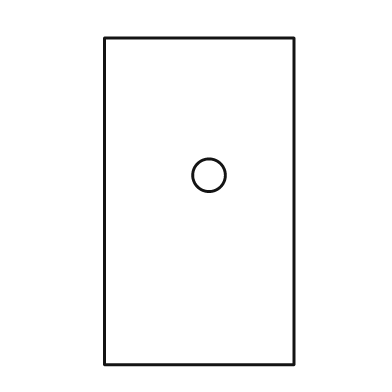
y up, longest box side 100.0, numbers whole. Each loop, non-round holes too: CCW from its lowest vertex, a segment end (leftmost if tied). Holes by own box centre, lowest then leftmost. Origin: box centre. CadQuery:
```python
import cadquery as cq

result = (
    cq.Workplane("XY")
    .moveTo(-29.0, -50.0)
    .lineTo(29.0, -50.0)
    .lineTo(29.0, 50.0)
    .lineTo(-29.0, 50.0)
    .close()
    .moveTo(3.0, 8.0)
    .circle(5.0)
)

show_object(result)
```